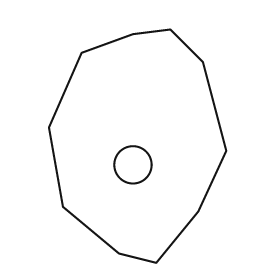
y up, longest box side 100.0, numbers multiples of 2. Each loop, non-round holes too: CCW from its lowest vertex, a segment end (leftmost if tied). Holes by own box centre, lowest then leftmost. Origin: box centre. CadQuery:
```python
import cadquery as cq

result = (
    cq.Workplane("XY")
    .moveTo(8.0, -50.0)
    .lineTo(26.0, -28.0)
    .lineTo(38.0, -2.0)
    .lineTo(28.0, 36.0)
    .lineTo(14.0, 50.0)
    .lineTo(-2.0, 48.0)
    .lineTo(-24.0, 40.0)
    .lineTo(-38.0, 8.0)
    .lineTo(-32.0, -26.0)
    .lineTo(-8.0, -46.0)
    .close()
    .moveTo(-2.0, -8.0)
    .circle(8.0)
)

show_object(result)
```